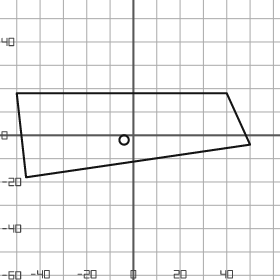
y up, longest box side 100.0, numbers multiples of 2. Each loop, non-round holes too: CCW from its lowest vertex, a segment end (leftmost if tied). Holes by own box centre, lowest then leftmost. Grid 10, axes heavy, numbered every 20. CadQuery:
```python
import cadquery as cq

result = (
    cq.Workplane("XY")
    .moveTo(-46.0, -18.0)
    .lineTo(50.0, -4.0)
    .lineTo(40.0, 18.0)
    .lineTo(-50.0, 18.0)
    .close()
    .moveTo(-4.0, -2.0)
    .circle(2.0)
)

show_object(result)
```